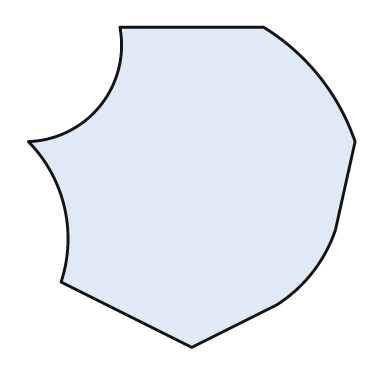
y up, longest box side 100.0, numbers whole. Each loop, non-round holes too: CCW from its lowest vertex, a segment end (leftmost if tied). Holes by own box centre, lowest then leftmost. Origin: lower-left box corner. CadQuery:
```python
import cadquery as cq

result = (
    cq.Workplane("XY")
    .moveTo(50.0, 0.0)
    .lineTo(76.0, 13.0)
    .threePointArc((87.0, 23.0), (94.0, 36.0))
    .lineTo(100.0, 63.0)
    .threePointArc((89.0, 83.0), (72.0, 98.0))
    .lineTo(28.0, 98.0)
    .threePointArc((22.0, 74.0), (0.0, 63.0))
    .threePointArc((11.0, 43.0), (10.0, 20.0))
    .close()
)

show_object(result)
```